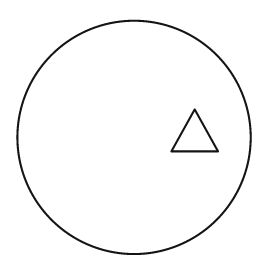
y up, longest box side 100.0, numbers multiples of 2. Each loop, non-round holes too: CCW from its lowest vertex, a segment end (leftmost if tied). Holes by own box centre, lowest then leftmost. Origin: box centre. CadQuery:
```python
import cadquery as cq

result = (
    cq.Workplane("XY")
    .moveTo(0.0, 0.0)
    .circle(50.0)
    .moveTo(16.0, -6.0)
    .lineTo(36.0, -6.0)
    .lineTo(26.0, 12.0)
    .close()
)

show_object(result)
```